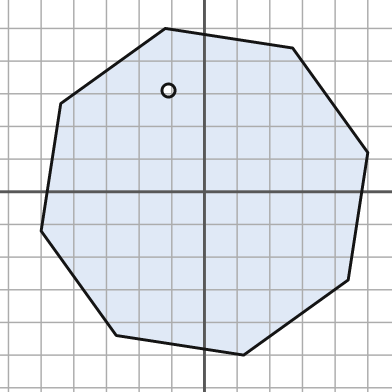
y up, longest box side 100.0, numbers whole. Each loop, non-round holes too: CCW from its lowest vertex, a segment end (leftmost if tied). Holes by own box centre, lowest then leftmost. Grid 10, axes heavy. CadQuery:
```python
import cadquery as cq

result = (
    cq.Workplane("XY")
    .moveTo(12.0, -50.0)
    .lineTo(44.0, -27.0)
    .lineTo(50.0, 12.0)
    .lineTo(27.0, 44.0)
    .lineTo(-12.0, 50.0)
    .lineTo(-44.0, 27.0)
    .lineTo(-50.0, -12.0)
    .lineTo(-27.0, -44.0)
    .close()
    .moveTo(-11.0, 31.0)
    .circle(2.0)
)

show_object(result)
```